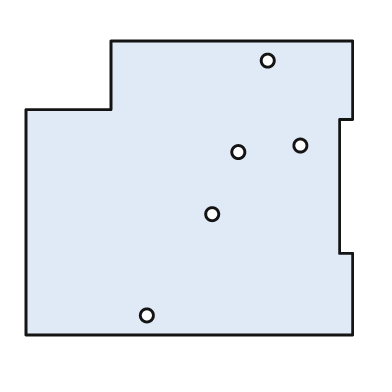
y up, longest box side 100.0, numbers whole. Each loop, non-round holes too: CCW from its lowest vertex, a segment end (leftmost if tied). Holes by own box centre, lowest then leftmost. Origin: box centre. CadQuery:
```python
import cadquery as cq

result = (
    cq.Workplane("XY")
    .moveTo(-50.0, -45.0)
    .lineTo(50.0, -45.0)
    .lineTo(50.0, -20.0)
    .lineTo(46.0, -20.0)
    .lineTo(46.0, 21.0)
    .lineTo(50.0, 21.0)
    .lineTo(50.0, 45.0)
    .lineTo(-24.0, 45.0)
    .lineTo(-24.0, 24.0)
    .lineTo(-50.0, 24.0)
    .close()
    .moveTo(-13.0, -39.0)
    .circle(2.0)
    .moveTo(7.0, -8.0)
    .circle(2.0)
    .moveTo(15.0, 11.0)
    .circle(2.0)
    .moveTo(34.0, 13.0)
    .circle(2.0)
    .moveTo(24.0, 39.0)
    .circle(2.0)
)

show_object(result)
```